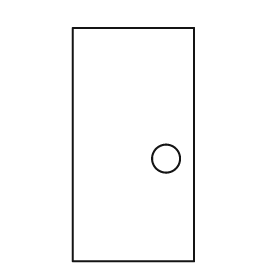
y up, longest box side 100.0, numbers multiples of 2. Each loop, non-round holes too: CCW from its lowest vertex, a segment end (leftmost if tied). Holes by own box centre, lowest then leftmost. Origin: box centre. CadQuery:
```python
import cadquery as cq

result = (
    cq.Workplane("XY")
    .moveTo(-26.0, -50.0)
    .lineTo(26.0, -50.0)
    .lineTo(26.0, 50.0)
    .lineTo(-26.0, 50.0)
    .close()
    .moveTo(14.0, -6.0)
    .circle(6.0)
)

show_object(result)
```